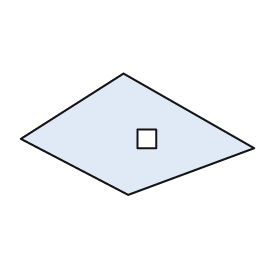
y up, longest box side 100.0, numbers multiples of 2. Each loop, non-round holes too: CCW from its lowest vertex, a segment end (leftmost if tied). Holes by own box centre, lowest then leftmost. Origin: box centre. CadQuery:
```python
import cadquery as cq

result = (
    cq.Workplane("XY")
    .moveTo(-4.0, -26.0)
    .lineTo(50.0, -6.0)
    .lineTo(-6.0, 26.0)
    .lineTo(-50.0, -2.0)
    .close()
    .moveTo(0.0, -6.0)
    .lineTo(8.0, -6.0)
    .lineTo(8.0, 2.0)
    .lineTo(0.0, 2.0)
    .close()
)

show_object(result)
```